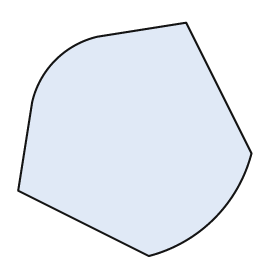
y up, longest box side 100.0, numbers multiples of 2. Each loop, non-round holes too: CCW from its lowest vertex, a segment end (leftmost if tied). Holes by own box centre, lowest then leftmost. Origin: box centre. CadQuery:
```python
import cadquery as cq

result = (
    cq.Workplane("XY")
    .moveTo(6.0, -50.0)
    .threePointArc((34.0, -34.0), (50.0, -6.0))
    .lineTo(22.0, 50.0)
    .lineTo(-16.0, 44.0)
    .threePointArc((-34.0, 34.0), (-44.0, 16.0))
    .lineTo(-50.0, -22.0)
    .close()
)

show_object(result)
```